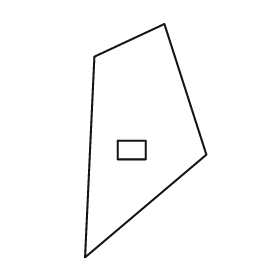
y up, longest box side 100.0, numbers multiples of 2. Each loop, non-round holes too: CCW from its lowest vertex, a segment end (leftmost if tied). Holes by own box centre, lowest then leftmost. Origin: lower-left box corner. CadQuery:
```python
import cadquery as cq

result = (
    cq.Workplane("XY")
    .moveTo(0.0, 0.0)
    .lineTo(52.0, 44.0)
    .lineTo(34.0, 100.0)
    .lineTo(4.0, 86.0)
    .close()
    .moveTo(14.0, 42.0)
    .lineTo(26.0, 42.0)
    .lineTo(26.0, 50.0)
    .lineTo(14.0, 50.0)
    .close()
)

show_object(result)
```